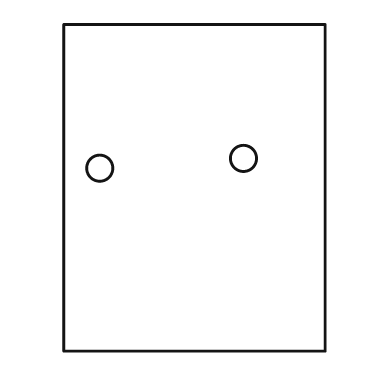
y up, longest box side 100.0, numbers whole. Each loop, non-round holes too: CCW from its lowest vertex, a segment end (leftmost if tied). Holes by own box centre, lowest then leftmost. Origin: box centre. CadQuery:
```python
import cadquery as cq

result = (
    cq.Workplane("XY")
    .moveTo(-40.0, -50.0)
    .lineTo(40.0, -50.0)
    .lineTo(40.0, 50.0)
    .lineTo(-40.0, 50.0)
    .close()
    .moveTo(-29.0, 6.0)
    .circle(4.0)
    .moveTo(15.0, 9.0)
    .circle(4.0)
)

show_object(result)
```